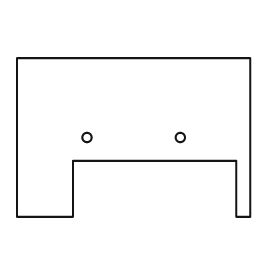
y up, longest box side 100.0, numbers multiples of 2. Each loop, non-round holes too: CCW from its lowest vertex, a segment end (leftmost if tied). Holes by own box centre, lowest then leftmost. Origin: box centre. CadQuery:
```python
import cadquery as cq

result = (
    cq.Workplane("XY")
    .moveTo(-50.0, -34.0)
    .lineTo(-26.0, -34.0)
    .lineTo(-26.0, -10.0)
    .lineTo(44.0, -10.0)
    .lineTo(44.0, -34.0)
    .lineTo(50.0, -34.0)
    .lineTo(50.0, 34.0)
    .lineTo(-50.0, 34.0)
    .close()
    .moveTo(-20.0, 0.0)
    .circle(2.0)
    .moveTo(20.0, 0.0)
    .circle(2.0)
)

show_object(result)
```